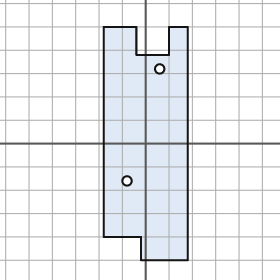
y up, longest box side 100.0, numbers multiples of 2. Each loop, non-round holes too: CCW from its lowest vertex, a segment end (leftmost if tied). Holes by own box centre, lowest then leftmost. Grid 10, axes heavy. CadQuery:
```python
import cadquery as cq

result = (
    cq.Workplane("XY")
    .moveTo(-2.0, -50.0)
    .lineTo(18.0, -50.0)
    .lineTo(18.0, 50.0)
    .lineTo(10.0, 50.0)
    .lineTo(10.0, 38.0)
    .lineTo(-4.0, 38.0)
    .lineTo(-4.0, 50.0)
    .lineTo(-18.0, 50.0)
    .lineTo(-18.0, -40.0)
    .lineTo(-2.0, -40.0)
    .close()
    .moveTo(-8.0, -16.0)
    .circle(2.0)
    .moveTo(6.0, 32.0)
    .circle(2.0)
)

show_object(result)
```